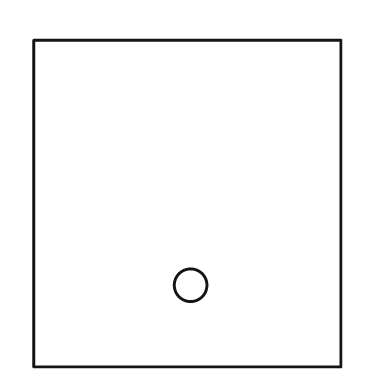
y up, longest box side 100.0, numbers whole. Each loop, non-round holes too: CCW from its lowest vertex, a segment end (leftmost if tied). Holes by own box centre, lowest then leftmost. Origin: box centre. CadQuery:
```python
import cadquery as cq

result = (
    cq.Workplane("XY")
    .moveTo(-47.0, -50.0)
    .lineTo(47.0, -50.0)
    .lineTo(47.0, 50.0)
    .lineTo(-47.0, 50.0)
    .close()
    .moveTo(1.0, -25.0)
    .circle(5.0)
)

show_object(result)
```